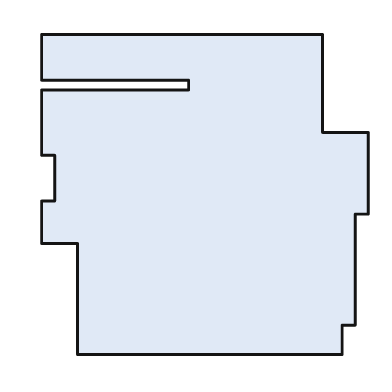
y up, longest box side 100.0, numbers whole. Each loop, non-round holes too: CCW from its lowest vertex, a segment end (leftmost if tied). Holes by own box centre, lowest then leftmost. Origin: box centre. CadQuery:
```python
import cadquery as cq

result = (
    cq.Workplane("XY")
    .moveTo(-39.0, -49.0)
    .lineTo(42.0, -49.0)
    .lineTo(42.0, -40.0)
    .lineTo(46.0, -40.0)
    .lineTo(46.0, -6.0)
    .lineTo(50.0, -6.0)
    .lineTo(50.0, 19.0)
    .lineTo(36.0, 19.0)
    .lineTo(36.0, 49.0)
    .lineTo(-50.0, 49.0)
    .lineTo(-50.0, 35.0)
    .lineTo(-5.0, 35.0)
    .lineTo(-5.0, 32.0)
    .lineTo(-50.0, 32.0)
    .lineTo(-50.0, 12.0)
    .lineTo(-46.0, 12.0)
    .lineTo(-46.0, -2.0)
    .lineTo(-50.0, -2.0)
    .lineTo(-50.0, -15.0)
    .lineTo(-39.0, -15.0)
    .close()
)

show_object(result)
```